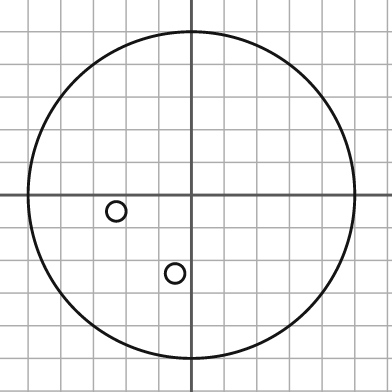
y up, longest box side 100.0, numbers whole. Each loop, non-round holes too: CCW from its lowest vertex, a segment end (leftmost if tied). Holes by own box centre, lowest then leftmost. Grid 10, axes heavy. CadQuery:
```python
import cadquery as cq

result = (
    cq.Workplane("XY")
    .moveTo(0.0, 0.0)
    .circle(50.0)
    .moveTo(-5.0, -24.0)
    .circle(3.0)
    .moveTo(-23.0, -5.0)
    .circle(3.0)
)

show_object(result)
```